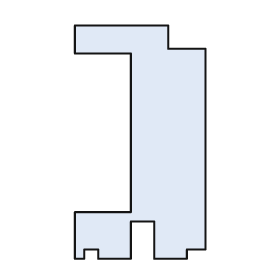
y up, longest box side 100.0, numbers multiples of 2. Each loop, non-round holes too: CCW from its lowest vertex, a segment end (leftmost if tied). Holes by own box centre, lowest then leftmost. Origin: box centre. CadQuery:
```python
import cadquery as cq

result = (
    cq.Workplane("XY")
    .moveTo(-28.0, -50.0)
    .lineTo(-24.0, -50.0)
    .lineTo(-24.0, -46.0)
    .lineTo(-18.0, -46.0)
    .lineTo(-18.0, -50.0)
    .lineTo(-4.0, -50.0)
    .lineTo(-4.0, -34.0)
    .lineTo(6.0, -34.0)
    .lineTo(6.0, -50.0)
    .lineTo(20.0, -50.0)
    .lineTo(20.0, -46.0)
    .lineTo(28.0, -46.0)
    .lineTo(28.0, 40.0)
    .lineTo(12.0, 40.0)
    .lineTo(12.0, 50.0)
    .lineTo(-28.0, 50.0)
    .lineTo(-28.0, 38.0)
    .lineTo(-4.0, 38.0)
    .lineTo(-4.0, -30.0)
    .lineTo(-28.0, -30.0)
    .close()
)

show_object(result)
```